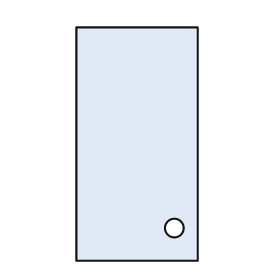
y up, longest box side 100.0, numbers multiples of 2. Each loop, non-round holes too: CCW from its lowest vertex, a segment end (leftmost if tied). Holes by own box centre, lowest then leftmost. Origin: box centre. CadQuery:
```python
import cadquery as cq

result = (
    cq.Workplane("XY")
    .moveTo(-26.0, -50.0)
    .lineTo(26.0, -50.0)
    .lineTo(26.0, 50.0)
    .lineTo(-26.0, 50.0)
    .close()
    .moveTo(16.0, -36.0)
    .circle(4.0)
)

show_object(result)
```